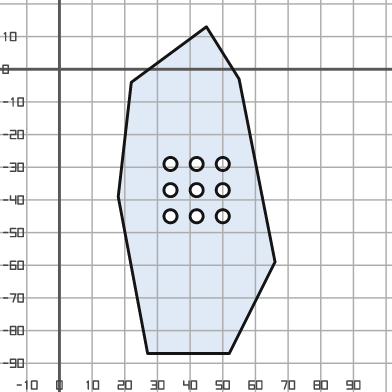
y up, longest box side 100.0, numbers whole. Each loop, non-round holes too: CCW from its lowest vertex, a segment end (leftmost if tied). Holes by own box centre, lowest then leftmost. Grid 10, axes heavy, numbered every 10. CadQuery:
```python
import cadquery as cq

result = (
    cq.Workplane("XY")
    .moveTo(27.0, -87.0)
    .lineTo(52.0, -87.0)
    .lineTo(66.0, -59.0)
    .lineTo(55.0, -3.0)
    .lineTo(45.0, 13.0)
    .lineTo(22.0, -4.0)
    .lineTo(18.0, -39.0)
    .close()
    .moveTo(34.0, -45.0)
    .circle(2.0)
    .moveTo(42.0, -45.0)
    .circle(2.0)
    .moveTo(50.0, -45.0)
    .circle(2.0)
    .moveTo(34.0, -37.0)
    .circle(2.0)
    .moveTo(42.0, -37.0)
    .circle(2.0)
    .moveTo(50.0, -37.0)
    .circle(2.0)
    .moveTo(34.0, -29.0)
    .circle(2.0)
    .moveTo(42.0, -29.0)
    .circle(2.0)
    .moveTo(50.0, -29.0)
    .circle(2.0)
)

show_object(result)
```